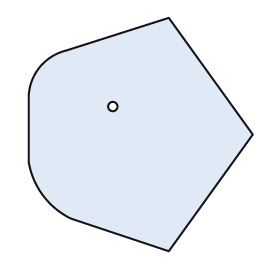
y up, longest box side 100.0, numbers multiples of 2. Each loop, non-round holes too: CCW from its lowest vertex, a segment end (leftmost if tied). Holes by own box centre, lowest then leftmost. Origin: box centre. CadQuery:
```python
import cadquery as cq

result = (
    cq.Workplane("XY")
    .moveTo(12.0, -50.0)
    .lineTo(48.0, 0.0)
    .lineTo(12.0, 50.0)
    .lineTo(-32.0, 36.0)
    .threePointArc((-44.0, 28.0), (-48.0, 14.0))
    .lineTo(-48.0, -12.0)
    .threePointArc((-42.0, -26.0), (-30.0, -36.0))
    .close()
    .moveTo(-12.0, 12.0)
    .circle(2.0)
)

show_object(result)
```